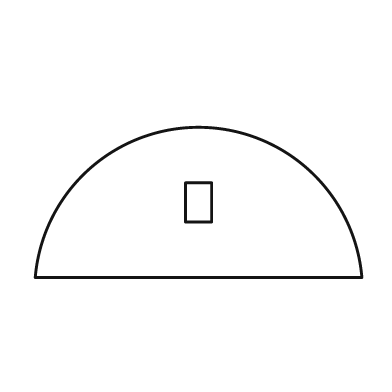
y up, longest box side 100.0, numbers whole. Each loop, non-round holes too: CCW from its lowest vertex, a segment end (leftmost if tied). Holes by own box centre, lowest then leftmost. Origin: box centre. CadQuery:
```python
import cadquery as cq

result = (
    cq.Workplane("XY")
    .moveTo(-50.0, -23.0)
    .lineTo(50.0, -23.0)
    .threePointArc((0.0, 23.0), (-50.0, -23.0))
    .close()
    .moveTo(-4.0, -6.0)
    .lineTo(4.0, -6.0)
    .lineTo(4.0, 6.0)
    .lineTo(-4.0, 6.0)
    .close()
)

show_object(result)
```